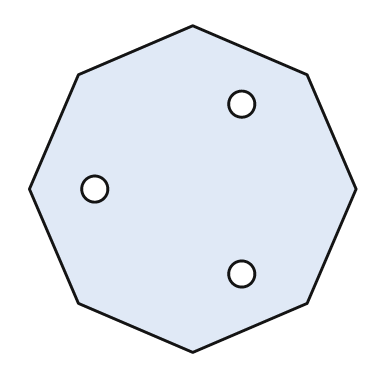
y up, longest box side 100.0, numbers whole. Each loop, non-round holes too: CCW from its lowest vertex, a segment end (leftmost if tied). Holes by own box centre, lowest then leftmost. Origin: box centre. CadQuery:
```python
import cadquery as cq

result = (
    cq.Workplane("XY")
    .moveTo(0.0, -50.0)
    .lineTo(35.0, -35.0)
    .lineTo(50.0, 0.0)
    .lineTo(35.0, 35.0)
    .lineTo(0.0, 50.0)
    .lineTo(-35.0, 35.0)
    .lineTo(-50.0, 0.0)
    .lineTo(-35.0, -35.0)
    .close()
    .moveTo(15.0, -26.0)
    .circle(4.0)
    .moveTo(-30.0, 0.0)
    .circle(4.0)
    .moveTo(15.0, 26.0)
    .circle(4.0)
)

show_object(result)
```